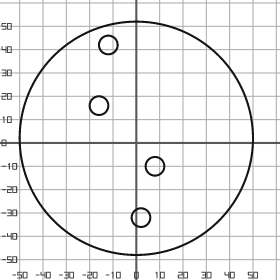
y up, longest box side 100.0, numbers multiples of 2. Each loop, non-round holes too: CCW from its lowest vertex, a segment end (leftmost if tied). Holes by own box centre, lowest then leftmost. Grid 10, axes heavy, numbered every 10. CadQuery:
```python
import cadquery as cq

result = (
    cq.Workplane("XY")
    .moveTo(0.0, 2.0)
    .circle(50.0)
    .moveTo(2.0, -32.0)
    .circle(4.0)
    .moveTo(8.0, -10.0)
    .circle(4.0)
    .moveTo(-16.0, 16.0)
    .circle(4.0)
    .moveTo(-12.0, 42.0)
    .circle(4.0)
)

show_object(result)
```